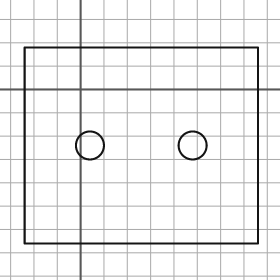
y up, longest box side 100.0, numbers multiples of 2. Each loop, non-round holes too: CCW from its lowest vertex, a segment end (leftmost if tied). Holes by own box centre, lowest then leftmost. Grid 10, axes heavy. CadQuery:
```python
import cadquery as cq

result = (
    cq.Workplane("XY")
    .moveTo(-24.0, -66.0)
    .lineTo(76.0, -66.0)
    .lineTo(76.0, 18.0)
    .lineTo(-24.0, 18.0)
    .close()
    .moveTo(4.0, -24.0)
    .circle(6.0)
    .moveTo(48.0, -24.0)
    .circle(6.0)
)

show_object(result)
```